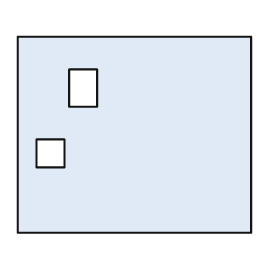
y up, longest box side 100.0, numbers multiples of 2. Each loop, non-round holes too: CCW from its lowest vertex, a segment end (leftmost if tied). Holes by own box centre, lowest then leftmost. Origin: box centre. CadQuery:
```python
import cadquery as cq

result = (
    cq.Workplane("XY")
    .moveTo(-50.0, -42.0)
    .lineTo(50.0, -42.0)
    .lineTo(50.0, 42.0)
    .lineTo(-50.0, 42.0)
    .close()
    .moveTo(-42.0, -14.0)
    .lineTo(-30.0, -14.0)
    .lineTo(-30.0, -2.0)
    .lineTo(-42.0, -2.0)
    .close()
    .moveTo(-28.0, 12.0)
    .lineTo(-16.0, 12.0)
    .lineTo(-16.0, 28.0)
    .lineTo(-28.0, 28.0)
    .close()
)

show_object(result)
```